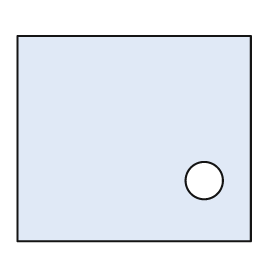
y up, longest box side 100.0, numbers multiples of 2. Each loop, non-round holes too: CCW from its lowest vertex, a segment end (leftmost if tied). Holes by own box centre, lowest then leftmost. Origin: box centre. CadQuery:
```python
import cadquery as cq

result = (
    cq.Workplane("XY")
    .moveTo(-50.0, -44.0)
    .lineTo(50.0, -44.0)
    .lineTo(50.0, 44.0)
    .lineTo(-50.0, 44.0)
    .close()
    .moveTo(30.0, -18.0)
    .circle(8.0)
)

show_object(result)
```